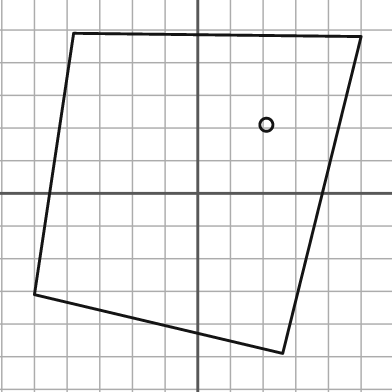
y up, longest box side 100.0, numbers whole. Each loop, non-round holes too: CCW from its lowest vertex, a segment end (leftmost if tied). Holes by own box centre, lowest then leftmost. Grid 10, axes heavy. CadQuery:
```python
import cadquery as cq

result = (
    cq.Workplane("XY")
    .moveTo(26.0, -49.0)
    .lineTo(50.0, 48.0)
    .lineTo(-38.0, 49.0)
    .lineTo(-50.0, -31.0)
    .close()
    .moveTo(21.0, 21.0)
    .circle(2.0)
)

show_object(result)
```